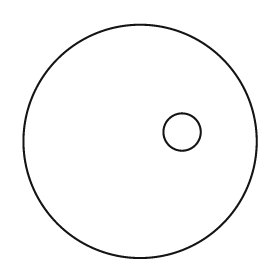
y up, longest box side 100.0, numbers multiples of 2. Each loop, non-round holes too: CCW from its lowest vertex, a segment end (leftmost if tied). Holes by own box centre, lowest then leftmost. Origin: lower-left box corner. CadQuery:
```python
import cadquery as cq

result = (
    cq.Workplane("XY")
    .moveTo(50.0, 50.0)
    .circle(50.0)
    .moveTo(68.0, 54.0)
    .circle(8.0)
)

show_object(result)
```